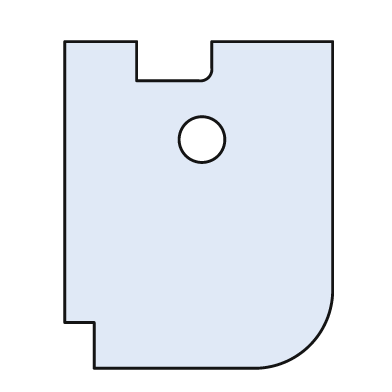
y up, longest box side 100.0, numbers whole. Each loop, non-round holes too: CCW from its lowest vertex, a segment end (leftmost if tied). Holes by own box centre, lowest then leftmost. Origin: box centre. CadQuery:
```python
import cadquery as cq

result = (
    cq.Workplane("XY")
    .moveTo(-32.0, -50.0)
    .lineTo(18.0, -50.0)
    .threePointArc((34.0, -43.0), (41.0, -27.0))
    .lineTo(41.0, 50.0)
    .lineTo(4.0, 50.0)
    .lineTo(4.0, 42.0)
    .threePointArc((3.0, 39.0), (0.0, 38.0))
    .lineTo(-19.0, 38.0)
    .lineTo(-19.0, 50.0)
    .lineTo(-41.0, 50.0)
    .lineTo(-41.0, -36.0)
    .lineTo(-32.0, -36.0)
    .close()
    .moveTo(1.0, 20.0)
    .circle(7.0)
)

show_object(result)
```